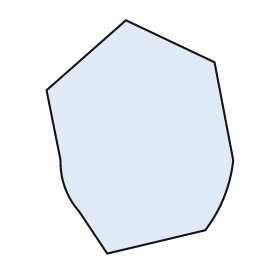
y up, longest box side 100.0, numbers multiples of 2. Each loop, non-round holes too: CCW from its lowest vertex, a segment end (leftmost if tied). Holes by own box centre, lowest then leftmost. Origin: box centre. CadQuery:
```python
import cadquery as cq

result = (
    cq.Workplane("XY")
    .moveTo(-14.0, -50.0)
    .lineTo(28.0, -40.0)
    .threePointArc((36.0, -26.0), (40.0, -10.0))
    .lineTo(32.0, 32.0)
    .lineTo(-6.0, 50.0)
    .lineTo(-40.0, 20.0)
    .lineTo(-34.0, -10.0)
    .threePointArc((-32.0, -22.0), (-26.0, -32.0))
    .close()
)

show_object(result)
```